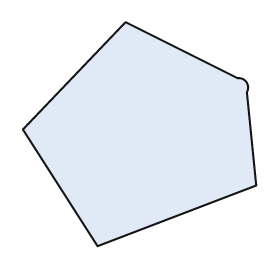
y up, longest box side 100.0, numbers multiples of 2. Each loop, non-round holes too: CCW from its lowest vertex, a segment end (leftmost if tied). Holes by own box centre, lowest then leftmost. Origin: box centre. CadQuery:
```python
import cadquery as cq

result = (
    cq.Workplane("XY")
    .moveTo(-18.0, -48.0)
    .lineTo(50.0, -22.0)
    .lineTo(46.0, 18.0)
    .threePointArc((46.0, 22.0), (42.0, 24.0))
    .lineTo(-6.0, 48.0)
    .lineTo(-50.0, 2.0)
    .close()
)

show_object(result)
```